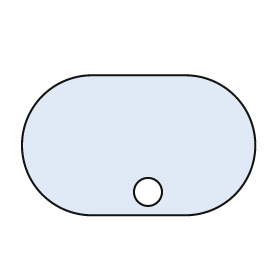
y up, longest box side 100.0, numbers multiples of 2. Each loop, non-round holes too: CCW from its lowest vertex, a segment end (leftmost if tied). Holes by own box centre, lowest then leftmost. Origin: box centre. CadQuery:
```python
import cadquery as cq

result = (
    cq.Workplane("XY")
    .moveTo(-20.0, -30.0)
    .lineTo(20.0, -30.0)
    .threePointArc((50.0, 0.0), (20.0, 30.0))
    .lineTo(-20.0, 30.0)
    .threePointArc((-50.0, 0.0), (-20.0, -30.0))
    .close()
    .moveTo(4.0, -20.0)
    .circle(6.0)
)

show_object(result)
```